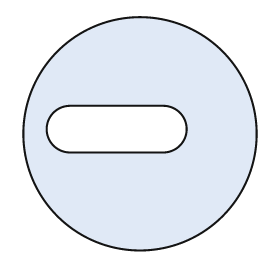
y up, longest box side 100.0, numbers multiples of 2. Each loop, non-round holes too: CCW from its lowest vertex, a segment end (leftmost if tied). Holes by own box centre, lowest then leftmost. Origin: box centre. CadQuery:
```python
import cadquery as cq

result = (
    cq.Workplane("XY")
    .moveTo(0.0, 0.0)
    .circle(50.0)
    .moveTo(-30.0, -8.0)
    .lineTo(10.0, -8.0)
    .threePointArc((20.0, 2.0), (10.0, 12.0))
    .lineTo(-30.0, 12.0)
    .threePointArc((-40.0, 2.0), (-30.0, -8.0))
    .close()
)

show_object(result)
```